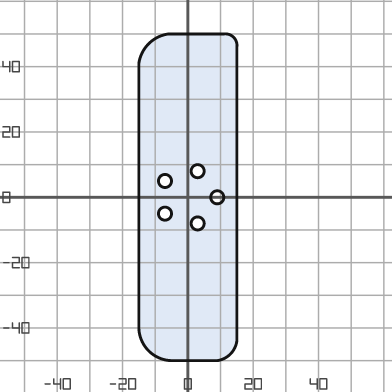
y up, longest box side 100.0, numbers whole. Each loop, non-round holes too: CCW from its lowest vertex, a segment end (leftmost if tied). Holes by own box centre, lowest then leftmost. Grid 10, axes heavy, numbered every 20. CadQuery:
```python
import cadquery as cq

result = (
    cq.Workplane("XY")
    .moveTo(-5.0, -50.0)
    .lineTo(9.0, -50.0)
    .threePointArc((13.0, -48.0), (15.0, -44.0))
    .lineTo(15.0, 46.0)
    .threePointArc((14.0, 49.0), (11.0, 50.0))
    .lineTo(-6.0, 50.0)
    .threePointArc((-12.0, 47.0), (-15.0, 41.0))
    .lineTo(-15.0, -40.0)
    .threePointArc((-12.0, -47.0), (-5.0, -50.0))
    .close()
    .moveTo(3.0, -8.0)
    .circle(2.0)
    .moveTo(-7.0, -5.0)
    .circle(2.0)
    .moveTo(9.0, 0.0)
    .circle(2.0)
    .moveTo(-7.0, 5.0)
    .circle(2.0)
    .moveTo(3.0, 8.0)
    .circle(2.0)
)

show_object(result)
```